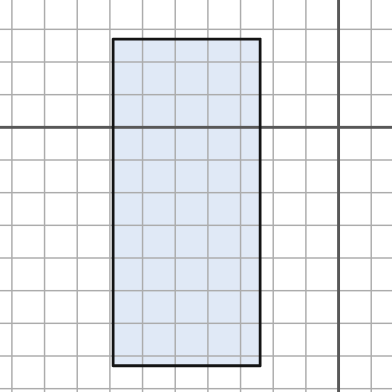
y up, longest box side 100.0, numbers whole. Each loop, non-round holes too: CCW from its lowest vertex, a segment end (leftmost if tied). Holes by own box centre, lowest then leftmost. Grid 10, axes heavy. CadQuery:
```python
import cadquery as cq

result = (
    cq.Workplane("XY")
    .moveTo(-69.0, -73.0)
    .lineTo(-24.0, -73.0)
    .lineTo(-24.0, 27.0)
    .lineTo(-69.0, 27.0)
    .close()
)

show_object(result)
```